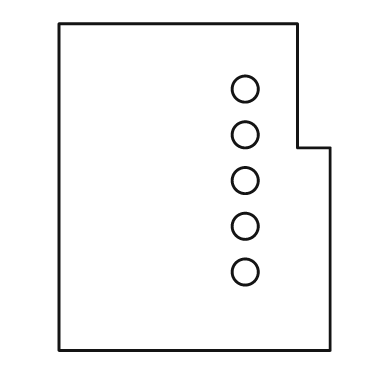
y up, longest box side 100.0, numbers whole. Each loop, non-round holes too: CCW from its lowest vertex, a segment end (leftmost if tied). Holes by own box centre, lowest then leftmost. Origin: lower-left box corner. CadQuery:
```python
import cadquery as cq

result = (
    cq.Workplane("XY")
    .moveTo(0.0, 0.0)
    .lineTo(83.0, 0.0)
    .lineTo(83.0, 62.0)
    .lineTo(73.0, 62.0)
    .lineTo(73.0, 100.0)
    .lineTo(0.0, 100.0)
    .close()
    .moveTo(57.0, 24.0)
    .circle(4.0)
    .moveTo(57.0, 38.0)
    .circle(4.0)
    .moveTo(57.0, 52.0)
    .circle(4.0)
    .moveTo(57.0, 66.0)
    .circle(4.0)
    .moveTo(57.0, 80.0)
    .circle(4.0)
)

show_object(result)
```